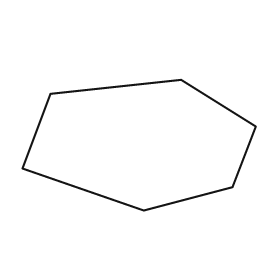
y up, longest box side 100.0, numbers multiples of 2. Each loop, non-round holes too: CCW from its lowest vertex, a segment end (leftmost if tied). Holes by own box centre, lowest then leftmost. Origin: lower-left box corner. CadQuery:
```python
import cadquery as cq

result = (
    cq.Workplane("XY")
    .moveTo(52.0, 0.0)
    .lineTo(90.0, 10.0)
    .lineTo(100.0, 36.0)
    .lineTo(68.0, 56.0)
    .lineTo(12.0, 50.0)
    .lineTo(0.0, 18.0)
    .close()
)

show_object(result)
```